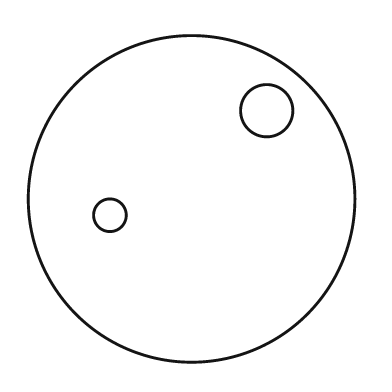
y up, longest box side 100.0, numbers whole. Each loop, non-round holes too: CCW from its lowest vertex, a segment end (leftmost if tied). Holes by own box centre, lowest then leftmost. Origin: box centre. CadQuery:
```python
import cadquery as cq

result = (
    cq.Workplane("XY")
    .moveTo(0.0, 0.0)
    .circle(50.0)
    .moveTo(-25.0, -5.0)
    .circle(5.0)
    .moveTo(23.0, 27.0)
    .circle(8.0)
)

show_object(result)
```